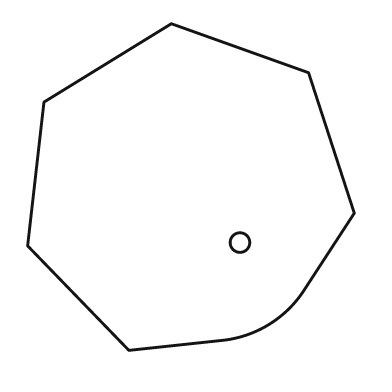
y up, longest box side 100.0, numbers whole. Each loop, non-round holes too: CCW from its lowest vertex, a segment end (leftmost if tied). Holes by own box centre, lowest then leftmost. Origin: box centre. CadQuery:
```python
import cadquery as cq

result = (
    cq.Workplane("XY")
    .moveTo(-19.0, -50.0)
    .lineTo(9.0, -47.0)
    .threePointArc((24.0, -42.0), (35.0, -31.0))
    .lineTo(50.0, -8.0)
    .lineTo(36.0, 35.0)
    .lineTo(-6.0, 50.0)
    .lineTo(-45.0, 26.0)
    .lineTo(-50.0, -18.0)
    .close()
    .moveTo(15.0, -17.0)
    .circle(3.0)
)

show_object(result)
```